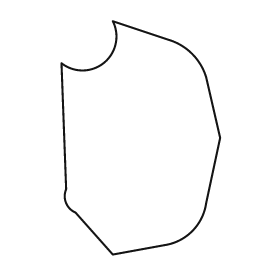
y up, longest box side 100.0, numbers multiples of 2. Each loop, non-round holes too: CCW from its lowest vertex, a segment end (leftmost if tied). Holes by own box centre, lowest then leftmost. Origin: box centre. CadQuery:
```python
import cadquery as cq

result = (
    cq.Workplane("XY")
    .moveTo(-12.0, -50.0)
    .lineTo(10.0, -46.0)
    .threePointArc((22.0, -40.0), (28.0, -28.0))
    .lineTo(34.0, 0.0)
    .lineTo(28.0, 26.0)
    .threePointArc((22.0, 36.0), (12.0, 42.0))
    .lineTo(-12.0, 50.0)
    .threePointArc((-16.0, 32.0), (-34.0, 32.0))
    .lineTo(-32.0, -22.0)
    .threePointArc((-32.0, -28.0), (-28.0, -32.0))
    .close()
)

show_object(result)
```